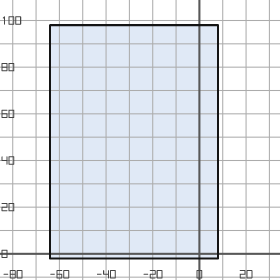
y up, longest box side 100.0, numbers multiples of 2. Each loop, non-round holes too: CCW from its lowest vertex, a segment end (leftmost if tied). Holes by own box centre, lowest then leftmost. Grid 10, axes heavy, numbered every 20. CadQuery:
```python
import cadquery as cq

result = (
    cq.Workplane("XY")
    .moveTo(-64.0, -2.0)
    .lineTo(8.0, -2.0)
    .lineTo(8.0, 98.0)
    .lineTo(-64.0, 98.0)
    .close()
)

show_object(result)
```